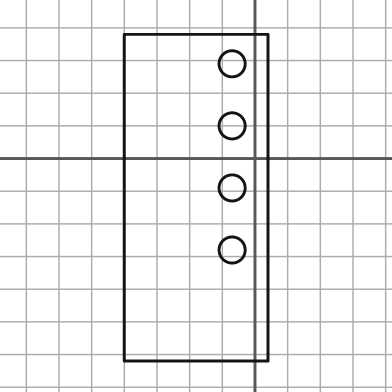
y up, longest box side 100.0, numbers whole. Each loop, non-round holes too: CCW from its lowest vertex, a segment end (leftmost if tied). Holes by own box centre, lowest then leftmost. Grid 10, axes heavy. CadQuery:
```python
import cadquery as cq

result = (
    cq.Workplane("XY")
    .moveTo(-40.0, -62.0)
    .lineTo(4.0, -62.0)
    .lineTo(4.0, 38.0)
    .lineTo(-40.0, 38.0)
    .close()
    .moveTo(-7.0, -28.0)
    .circle(4.0)
    .moveTo(-7.0, -9.0)
    .circle(4.0)
    .moveTo(-7.0, 10.0)
    .circle(4.0)
    .moveTo(-7.0, 29.0)
    .circle(4.0)
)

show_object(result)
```